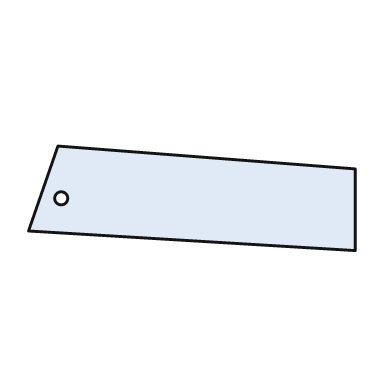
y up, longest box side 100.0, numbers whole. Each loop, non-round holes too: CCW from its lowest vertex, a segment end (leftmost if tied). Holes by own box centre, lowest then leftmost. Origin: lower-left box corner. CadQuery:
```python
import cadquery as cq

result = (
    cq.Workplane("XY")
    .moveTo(100.0, 0.0)
    .lineTo(100.0, 25.0)
    .lineTo(9.0, 32.0)
    .lineTo(0.0, 6.0)
    .close()
    .moveTo(10.0, 16.0)
    .circle(2.0)
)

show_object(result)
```